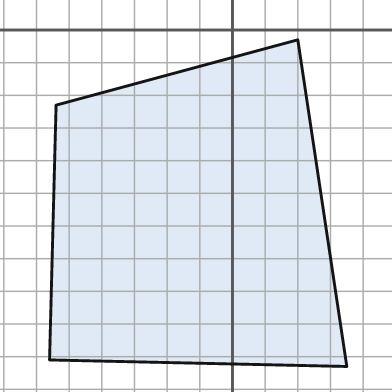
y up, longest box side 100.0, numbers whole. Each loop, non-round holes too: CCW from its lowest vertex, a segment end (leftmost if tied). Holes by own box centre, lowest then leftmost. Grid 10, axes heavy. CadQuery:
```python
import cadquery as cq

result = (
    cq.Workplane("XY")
    .moveTo(35.0, -103.0)
    .lineTo(20.0, -3.0)
    .lineTo(-54.0, -23.0)
    .lineTo(-56.0, -101.0)
    .close()
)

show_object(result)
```